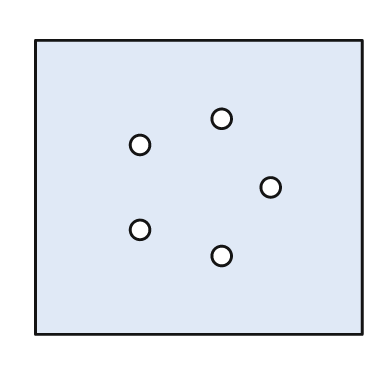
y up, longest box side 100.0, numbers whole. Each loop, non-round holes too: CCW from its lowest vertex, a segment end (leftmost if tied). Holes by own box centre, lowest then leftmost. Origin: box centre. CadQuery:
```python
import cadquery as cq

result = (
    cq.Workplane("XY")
    .moveTo(-50.0, -45.0)
    .lineTo(50.0, -45.0)
    .lineTo(50.0, 45.0)
    .lineTo(-50.0, 45.0)
    .close()
    .moveTo(7.0, -21.0)
    .circle(3.0)
    .moveTo(-18.0, -13.0)
    .circle(3.0)
    .moveTo(22.0, 0.0)
    .circle(3.0)
    .moveTo(-18.0, 13.0)
    .circle(3.0)
    .moveTo(7.0, 21.0)
    .circle(3.0)
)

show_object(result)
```